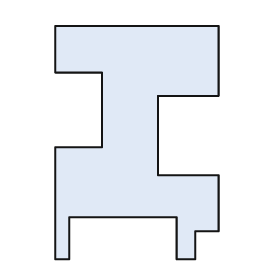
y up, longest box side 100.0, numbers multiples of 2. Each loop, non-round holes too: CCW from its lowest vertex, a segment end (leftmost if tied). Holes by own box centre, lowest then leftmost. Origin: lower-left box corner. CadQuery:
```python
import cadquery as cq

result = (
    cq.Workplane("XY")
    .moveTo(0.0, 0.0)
    .lineTo(6.0, 0.0)
    .lineTo(6.0, 18.0)
    .lineTo(52.0, 18.0)
    .lineTo(52.0, 0.0)
    .lineTo(60.0, 0.0)
    .lineTo(60.0, 12.0)
    .lineTo(70.0, 12.0)
    .lineTo(70.0, 36.0)
    .lineTo(44.0, 36.0)
    .lineTo(44.0, 70.0)
    .lineTo(70.0, 70.0)
    .lineTo(70.0, 100.0)
    .lineTo(0.0, 100.0)
    .lineTo(0.0, 80.0)
    .lineTo(20.0, 80.0)
    .lineTo(20.0, 48.0)
    .lineTo(0.0, 48.0)
    .close()
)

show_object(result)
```